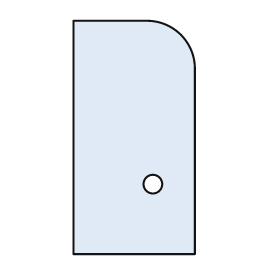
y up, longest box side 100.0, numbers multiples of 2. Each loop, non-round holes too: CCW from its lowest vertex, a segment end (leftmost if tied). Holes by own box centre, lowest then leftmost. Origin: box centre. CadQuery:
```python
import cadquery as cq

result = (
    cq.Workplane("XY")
    .moveTo(-26.0, -50.0)
    .lineTo(26.0, -50.0)
    .lineTo(26.0, 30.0)
    .threePointArc((20.0, 44.0), (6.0, 50.0))
    .lineTo(-26.0, 50.0)
    .close()
    .moveTo(8.0, -20.0)
    .circle(4.0)
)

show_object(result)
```